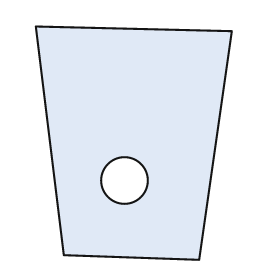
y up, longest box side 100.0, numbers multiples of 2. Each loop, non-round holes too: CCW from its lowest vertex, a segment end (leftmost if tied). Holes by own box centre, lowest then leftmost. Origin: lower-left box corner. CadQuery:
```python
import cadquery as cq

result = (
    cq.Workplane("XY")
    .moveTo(70.0, 0.0)
    .lineTo(84.0, 98.0)
    .lineTo(0.0, 100.0)
    .lineTo(12.0, 2.0)
    .close()
    .moveTo(38.0, 34.0)
    .circle(10.0)
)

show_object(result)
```